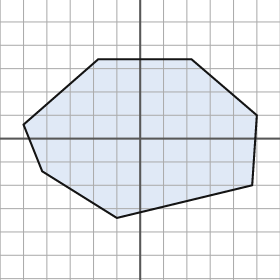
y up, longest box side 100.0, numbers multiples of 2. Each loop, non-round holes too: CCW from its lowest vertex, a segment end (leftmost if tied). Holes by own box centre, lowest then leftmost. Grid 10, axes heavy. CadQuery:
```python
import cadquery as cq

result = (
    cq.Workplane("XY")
    .moveTo(-10.0, -34.0)
    .lineTo(48.0, -20.0)
    .lineTo(50.0, 10.0)
    .lineTo(22.0, 34.0)
    .lineTo(-18.0, 34.0)
    .lineTo(-50.0, 6.0)
    .lineTo(-42.0, -14.0)
    .close()
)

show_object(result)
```